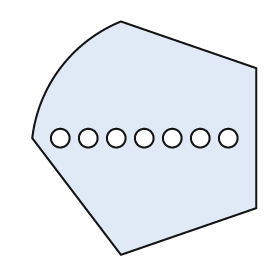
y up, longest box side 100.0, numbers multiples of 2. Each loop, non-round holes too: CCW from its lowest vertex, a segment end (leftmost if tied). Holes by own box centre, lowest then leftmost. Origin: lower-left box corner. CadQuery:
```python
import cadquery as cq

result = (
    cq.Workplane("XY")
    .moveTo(38.0, 0.0)
    .lineTo(96.0, 20.0)
    .lineTo(96.0, 80.0)
    .lineTo(38.0, 100.0)
    .threePointArc((12.0, 80.0), (0.0, 50.0))
    .close()
    .moveTo(12.0, 50.0)
    .circle(4.0)
    .moveTo(24.0, 50.0)
    .circle(4.0)
    .moveTo(36.0, 50.0)
    .circle(4.0)
    .moveTo(48.0, 50.0)
    .circle(4.0)
    .moveTo(60.0, 50.0)
    .circle(4.0)
    .moveTo(72.0, 50.0)
    .circle(4.0)
    .moveTo(84.0, 50.0)
    .circle(4.0)
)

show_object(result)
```